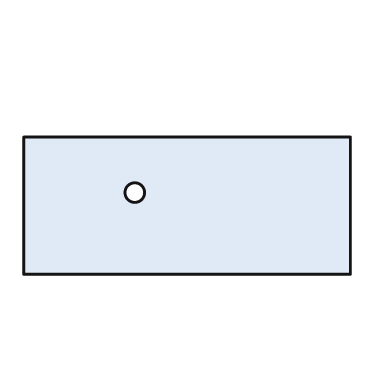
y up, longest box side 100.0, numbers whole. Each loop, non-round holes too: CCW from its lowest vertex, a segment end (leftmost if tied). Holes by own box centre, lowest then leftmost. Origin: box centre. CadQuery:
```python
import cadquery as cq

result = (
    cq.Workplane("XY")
    .moveTo(-50.0, -21.0)
    .lineTo(50.0, -21.0)
    .lineTo(50.0, 21.0)
    .lineTo(-50.0, 21.0)
    .close()
    .moveTo(-16.0, 4.0)
    .circle(3.0)
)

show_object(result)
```